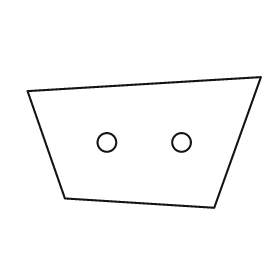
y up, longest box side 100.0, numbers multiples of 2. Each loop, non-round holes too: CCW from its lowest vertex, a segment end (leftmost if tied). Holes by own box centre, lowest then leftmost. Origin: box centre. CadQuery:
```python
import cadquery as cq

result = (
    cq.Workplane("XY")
    .moveTo(30.0, -28.0)
    .lineTo(50.0, 28.0)
    .lineTo(-50.0, 22.0)
    .lineTo(-34.0, -24.0)
    .close()
    .moveTo(-16.0, 0.0)
    .circle(4.0)
    .moveTo(16.0, 0.0)
    .circle(4.0)
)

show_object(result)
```